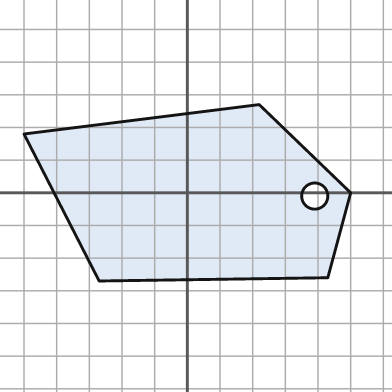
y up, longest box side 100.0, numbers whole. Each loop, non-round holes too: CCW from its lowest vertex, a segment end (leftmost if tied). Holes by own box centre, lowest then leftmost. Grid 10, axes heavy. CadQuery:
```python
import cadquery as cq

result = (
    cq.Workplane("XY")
    .moveTo(-27.0, -27.0)
    .lineTo(43.0, -26.0)
    .lineTo(50.0, 0.0)
    .lineTo(22.0, 27.0)
    .lineTo(-50.0, 18.0)
    .close()
    .moveTo(39.0, -1.0)
    .circle(4.0)
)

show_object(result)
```